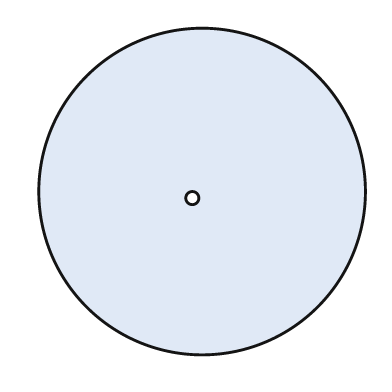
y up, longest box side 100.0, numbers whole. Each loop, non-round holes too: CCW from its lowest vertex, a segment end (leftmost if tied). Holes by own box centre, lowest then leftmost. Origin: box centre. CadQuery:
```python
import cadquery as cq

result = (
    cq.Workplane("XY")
    .moveTo(0.0, 0.0)
    .circle(50.0)
    .moveTo(-3.0, -2.0)
    .circle(2.0)
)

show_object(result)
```